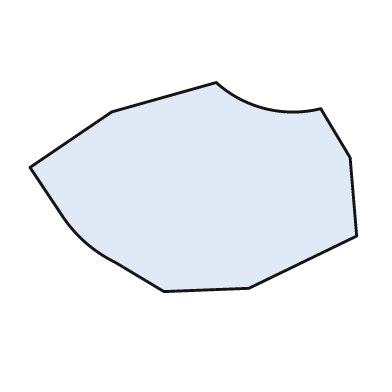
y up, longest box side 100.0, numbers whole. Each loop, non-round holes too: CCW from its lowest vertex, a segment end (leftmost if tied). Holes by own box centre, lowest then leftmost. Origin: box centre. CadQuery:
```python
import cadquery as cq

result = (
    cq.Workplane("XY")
    .moveTo(-9.0, -32.0)
    .lineTo(17.0, -31.0)
    .lineTo(50.0, -15.0)
    .lineTo(48.0, 9.0)
    .lineTo(39.0, 24.0)
    .threePointArc((22.0, 24.0), (7.0, 32.0))
    .lineTo(-25.0, 23.0)
    .lineTo(-50.0, 6.0)
    .lineTo(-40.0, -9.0)
    .threePointArc((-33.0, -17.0), (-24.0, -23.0))
    .close()
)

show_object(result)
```